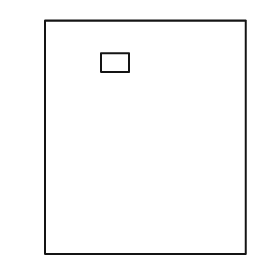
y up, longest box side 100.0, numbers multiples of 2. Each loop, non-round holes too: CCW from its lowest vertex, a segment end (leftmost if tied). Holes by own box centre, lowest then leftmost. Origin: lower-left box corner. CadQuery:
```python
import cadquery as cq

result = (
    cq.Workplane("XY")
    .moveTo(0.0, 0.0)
    .lineTo(86.0, 0.0)
    .lineTo(86.0, 100.0)
    .lineTo(0.0, 100.0)
    .close()
    .moveTo(24.0, 78.0)
    .lineTo(36.0, 78.0)
    .lineTo(36.0, 86.0)
    .lineTo(24.0, 86.0)
    .close()
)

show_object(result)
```